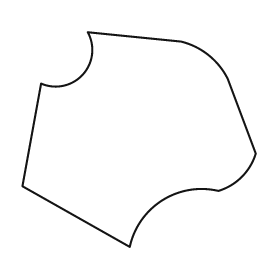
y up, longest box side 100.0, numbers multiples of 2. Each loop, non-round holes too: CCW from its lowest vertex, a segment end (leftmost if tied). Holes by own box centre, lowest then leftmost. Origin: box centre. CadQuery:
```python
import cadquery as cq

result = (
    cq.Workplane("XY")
    .moveTo(-4.0, -46.0)
    .threePointArc((10.0, -26.0), (34.0, -22.0))
    .threePointArc((44.0, -16.0), (50.0, -6.0))
    .lineTo(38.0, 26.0)
    .threePointArc((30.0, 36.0), (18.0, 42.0))
    .lineTo(-22.0, 46.0)
    .threePointArc((-24.0, 28.0), (-42.0, 24.0))
    .lineTo(-50.0, -20.0)
    .close()
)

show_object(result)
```